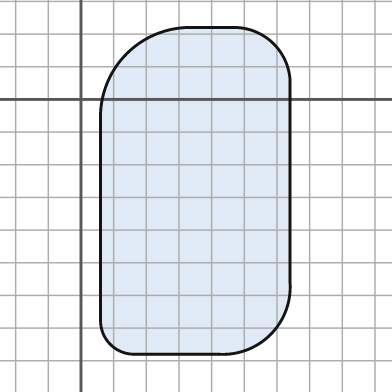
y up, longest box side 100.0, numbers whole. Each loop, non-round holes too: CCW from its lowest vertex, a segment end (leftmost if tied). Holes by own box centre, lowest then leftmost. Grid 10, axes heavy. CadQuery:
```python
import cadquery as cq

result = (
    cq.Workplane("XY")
    .moveTo(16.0, -78.0)
    .lineTo(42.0, -78.0)
    .threePointArc((58.0, -72.0), (64.0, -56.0))
    .lineTo(64.0, 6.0)
    .threePointArc((59.0, 17.0), (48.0, 22.0))
    .lineTo(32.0, 22.0)
    .threePointArc((14.0, 14.0), (6.0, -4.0))
    .lineTo(6.0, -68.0)
    .threePointArc((9.0, -75.0), (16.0, -78.0))
    .close()
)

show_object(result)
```